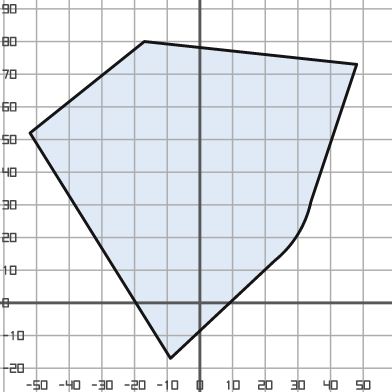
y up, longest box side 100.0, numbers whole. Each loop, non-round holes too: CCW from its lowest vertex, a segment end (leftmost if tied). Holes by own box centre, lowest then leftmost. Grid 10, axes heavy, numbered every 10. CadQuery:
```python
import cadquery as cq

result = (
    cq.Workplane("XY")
    .moveTo(-9.0, -17.0)
    .lineTo(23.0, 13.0)
    .threePointArc((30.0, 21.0), (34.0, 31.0))
    .lineTo(48.0, 73.0)
    .lineTo(-17.0, 80.0)
    .lineTo(-52.0, 52.0)
    .close()
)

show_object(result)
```